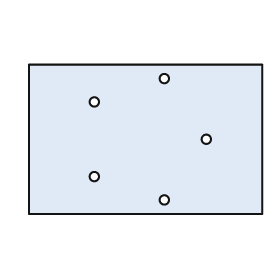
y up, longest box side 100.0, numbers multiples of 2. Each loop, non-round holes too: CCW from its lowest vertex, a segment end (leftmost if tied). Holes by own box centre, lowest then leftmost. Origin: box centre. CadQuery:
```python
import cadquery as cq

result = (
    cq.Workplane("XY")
    .moveTo(-50.0, -32.0)
    .lineTo(50.0, -32.0)
    .lineTo(50.0, 32.0)
    .lineTo(-50.0, 32.0)
    .close()
    .moveTo(8.0, -26.0)
    .circle(2.0)
    .moveTo(-22.0, -16.0)
    .circle(2.0)
    .moveTo(26.0, 0.0)
    .circle(2.0)
    .moveTo(-22.0, 16.0)
    .circle(2.0)
    .moveTo(8.0, 26.0)
    .circle(2.0)
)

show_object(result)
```